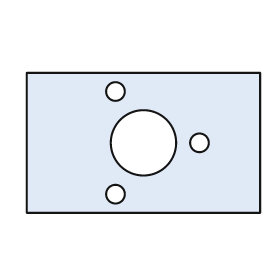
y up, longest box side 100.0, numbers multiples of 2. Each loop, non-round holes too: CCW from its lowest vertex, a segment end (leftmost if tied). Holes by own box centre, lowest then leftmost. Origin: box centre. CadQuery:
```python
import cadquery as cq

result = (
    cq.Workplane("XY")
    .moveTo(-50.0, -30.0)
    .lineTo(50.0, -30.0)
    .lineTo(50.0, 30.0)
    .lineTo(-50.0, 30.0)
    .close()
    .moveTo(-12.0, -22.0)
    .circle(4.0)
    .moveTo(0.0, 0.0)
    .circle(14.0)
    .moveTo(24.0, 0.0)
    .circle(4.0)
    .moveTo(-12.0, 22.0)
    .circle(4.0)
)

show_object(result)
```